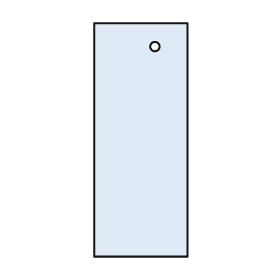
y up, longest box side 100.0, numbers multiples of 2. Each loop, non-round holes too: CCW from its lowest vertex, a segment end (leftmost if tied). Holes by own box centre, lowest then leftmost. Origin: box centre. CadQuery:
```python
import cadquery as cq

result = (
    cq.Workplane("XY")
    .moveTo(-20.0, -50.0)
    .lineTo(20.0, -50.0)
    .lineTo(20.0, 50.0)
    .lineTo(-20.0, 50.0)
    .close()
    .moveTo(6.0, 40.0)
    .circle(2.0)
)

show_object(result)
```